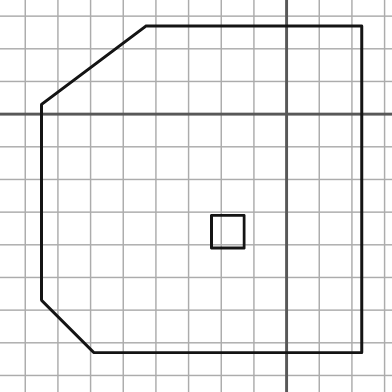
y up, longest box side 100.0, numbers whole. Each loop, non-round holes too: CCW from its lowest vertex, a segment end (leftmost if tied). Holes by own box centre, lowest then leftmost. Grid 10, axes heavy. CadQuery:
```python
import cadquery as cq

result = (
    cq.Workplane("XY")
    .moveTo(-59.0, -73.0)
    .lineTo(23.0, -73.0)
    .lineTo(23.0, 27.0)
    .lineTo(-43.0, 27.0)
    .lineTo(-75.0, 3.0)
    .lineTo(-75.0, -57.0)
    .close()
    .moveTo(-23.0, -41.0)
    .lineTo(-13.0, -41.0)
    .lineTo(-13.0, -31.0)
    .lineTo(-23.0, -31.0)
    .close()
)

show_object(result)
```